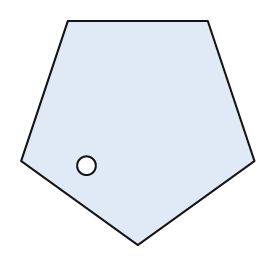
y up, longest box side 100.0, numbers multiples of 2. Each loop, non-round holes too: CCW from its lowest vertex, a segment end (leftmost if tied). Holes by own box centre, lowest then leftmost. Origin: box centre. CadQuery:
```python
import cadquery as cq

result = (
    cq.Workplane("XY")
    .moveTo(0.0, -48.0)
    .lineTo(50.0, -12.0)
    .lineTo(30.0, 48.0)
    .lineTo(-30.0, 48.0)
    .lineTo(-50.0, -12.0)
    .close()
    .moveTo(-22.0, -14.0)
    .circle(4.0)
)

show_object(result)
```